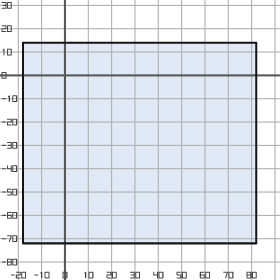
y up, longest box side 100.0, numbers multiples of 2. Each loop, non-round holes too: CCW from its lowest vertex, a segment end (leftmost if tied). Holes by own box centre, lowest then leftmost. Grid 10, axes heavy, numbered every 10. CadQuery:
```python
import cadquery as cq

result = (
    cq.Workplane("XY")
    .moveTo(-18.0, -72.0)
    .lineTo(82.0, -72.0)
    .lineTo(82.0, 14.0)
    .lineTo(-18.0, 14.0)
    .close()
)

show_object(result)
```